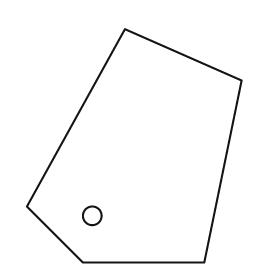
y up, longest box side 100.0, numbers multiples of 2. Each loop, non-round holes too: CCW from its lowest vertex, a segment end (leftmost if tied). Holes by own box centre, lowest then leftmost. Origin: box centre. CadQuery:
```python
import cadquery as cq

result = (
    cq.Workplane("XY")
    .moveTo(-22.0, -50.0)
    .lineTo(30.0, -50.0)
    .lineTo(46.0, 28.0)
    .lineTo(-4.0, 50.0)
    .lineTo(-46.0, -26.0)
    .close()
    .moveTo(-18.0, -30.0)
    .circle(4.0)
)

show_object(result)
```